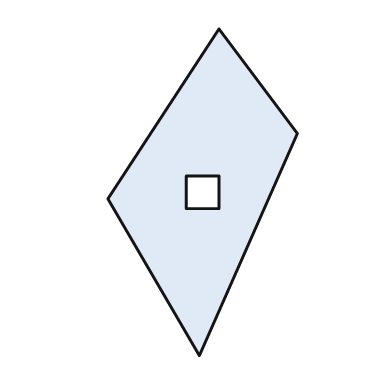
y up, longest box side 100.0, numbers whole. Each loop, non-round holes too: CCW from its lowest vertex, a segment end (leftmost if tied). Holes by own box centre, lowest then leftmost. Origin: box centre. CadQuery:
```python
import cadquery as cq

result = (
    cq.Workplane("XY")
    .moveTo(-1.0, -50.0)
    .lineTo(29.0, 18.0)
    .lineTo(5.0, 50.0)
    .lineTo(-29.0, -2.0)
    .close()
    .moveTo(-5.0, -5.0)
    .lineTo(5.0, -5.0)
    .lineTo(5.0, 5.0)
    .lineTo(-5.0, 5.0)
    .close()
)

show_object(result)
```